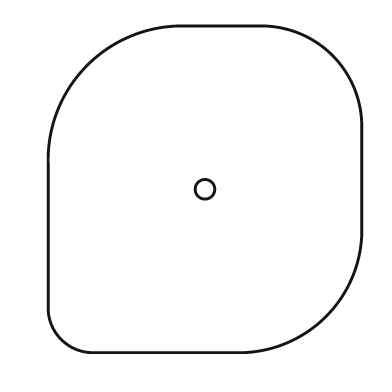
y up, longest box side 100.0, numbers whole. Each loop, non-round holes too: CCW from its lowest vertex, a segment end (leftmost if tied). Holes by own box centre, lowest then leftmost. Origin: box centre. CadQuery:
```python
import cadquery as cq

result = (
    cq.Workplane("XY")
    .moveTo(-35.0, -50.0)
    .lineTo(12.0, -50.0)
    .threePointArc((37.0, -39.0), (48.0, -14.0))
    .lineTo(48.0, 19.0)
    .threePointArc((39.0, 41.0), (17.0, 50.0))
    .lineTo(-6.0, 50.0)
    .threePointArc((-36.0, 38.0), (-48.0, 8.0))
    .lineTo(-48.0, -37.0)
    .threePointArc((-44.0, -46.0), (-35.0, -50.0))
    .close()
    .moveTo(0.0, 0.0)
    .circle(3.0)
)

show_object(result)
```